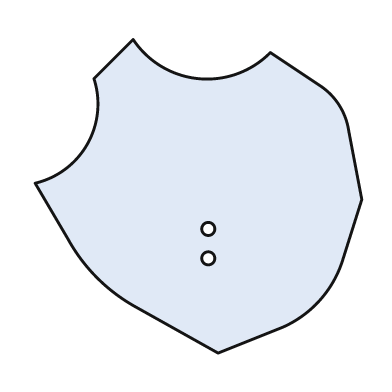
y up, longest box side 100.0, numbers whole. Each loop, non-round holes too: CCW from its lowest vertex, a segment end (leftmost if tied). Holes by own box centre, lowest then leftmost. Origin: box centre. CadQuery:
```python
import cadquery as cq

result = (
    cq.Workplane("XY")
    .moveTo(6.0, -48.0)
    .lineTo(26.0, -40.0)
    .threePointArc((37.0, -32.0), (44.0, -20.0))
    .lineTo(50.0, -1.0)
    .lineTo(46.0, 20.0)
    .threePointArc((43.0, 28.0), (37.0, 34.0))
    .lineTo(22.0, 44.0)
    .threePointArc((0.0, 36.0), (-20.0, 48.0))
    .lineTo(-32.0, 36.0)
    .threePointArc((-34.0, 16.0), (-50.0, 4.0))
    .lineTo(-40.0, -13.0)
    .threePointArc((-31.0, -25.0), (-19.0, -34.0))
    .close()
    .moveTo(3.0, -19.0)
    .circle(2.0)
    .moveTo(3.0, -10.0)
    .circle(2.0)
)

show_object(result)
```